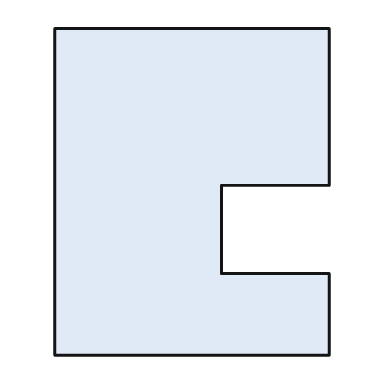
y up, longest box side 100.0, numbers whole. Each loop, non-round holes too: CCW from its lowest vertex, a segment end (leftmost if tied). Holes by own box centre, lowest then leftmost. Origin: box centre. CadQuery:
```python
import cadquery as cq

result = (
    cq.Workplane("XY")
    .moveTo(-42.0, -50.0)
    .lineTo(42.0, -50.0)
    .lineTo(42.0, -25.0)
    .lineTo(9.0, -25.0)
    .lineTo(9.0, 2.0)
    .lineTo(42.0, 2.0)
    .lineTo(42.0, 50.0)
    .lineTo(-42.0, 50.0)
    .close()
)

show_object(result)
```